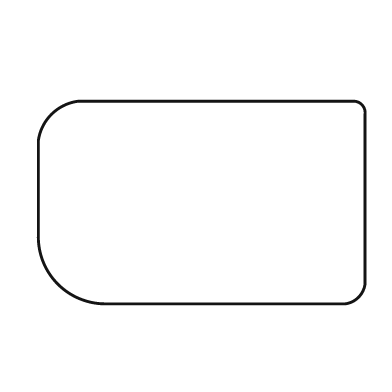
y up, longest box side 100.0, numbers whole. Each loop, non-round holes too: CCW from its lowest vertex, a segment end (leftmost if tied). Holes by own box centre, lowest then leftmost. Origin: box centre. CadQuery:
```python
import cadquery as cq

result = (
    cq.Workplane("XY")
    .moveTo(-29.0, -31.0)
    .lineTo(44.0, -31.0)
    .threePointArc((48.0, -29.0), (50.0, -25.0))
    .lineTo(50.0, 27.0)
    .threePointArc((49.0, 30.0), (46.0, 31.0))
    .lineTo(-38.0, 31.0)
    .threePointArc((-46.0, 27.0), (-50.0, 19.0))
    .lineTo(-50.0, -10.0)
    .threePointArc((-44.0, -25.0), (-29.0, -31.0))
    .close()
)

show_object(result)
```